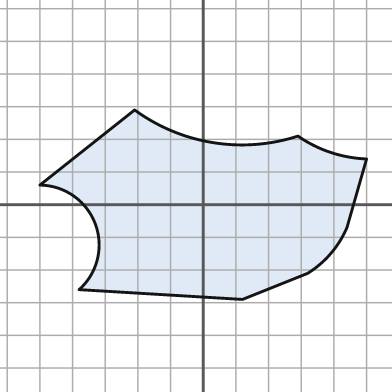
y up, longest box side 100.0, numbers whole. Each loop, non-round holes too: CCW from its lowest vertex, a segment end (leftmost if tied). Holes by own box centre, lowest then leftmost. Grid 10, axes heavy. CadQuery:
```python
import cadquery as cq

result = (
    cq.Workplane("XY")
    .moveTo(12.0, -29.0)
    .lineTo(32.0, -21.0)
    .threePointArc((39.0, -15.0), (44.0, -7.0))
    .lineTo(50.0, 14.0)
    .threePointArc((39.0, 16.0), (29.0, 21.0))
    .threePointArc((3.0, 19.0), (-21.0, 29.0))
    .lineTo(-50.0, 6.0)
    .threePointArc((-33.0, -6.0), (-38.0, -26.0))
    .close()
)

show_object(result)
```